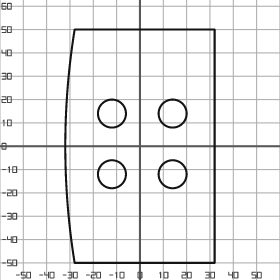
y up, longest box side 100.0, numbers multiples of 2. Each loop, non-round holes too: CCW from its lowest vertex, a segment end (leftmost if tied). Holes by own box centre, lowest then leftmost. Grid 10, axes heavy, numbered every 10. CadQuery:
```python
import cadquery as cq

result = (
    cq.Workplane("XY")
    .moveTo(-28.0, -50.0)
    .lineTo(32.0, -50.0)
    .lineTo(32.0, 50.0)
    .lineTo(-28.0, 50.0)
    .threePointArc((-32.0, 0.0), (-28.0, -50.0))
    .close()
    .moveTo(-12.0, -12.0)
    .circle(6.0)
    .moveTo(14.0, -12.0)
    .circle(6.0)
    .moveTo(-12.0, 14.0)
    .circle(6.0)
    .moveTo(14.0, 14.0)
    .circle(6.0)
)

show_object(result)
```